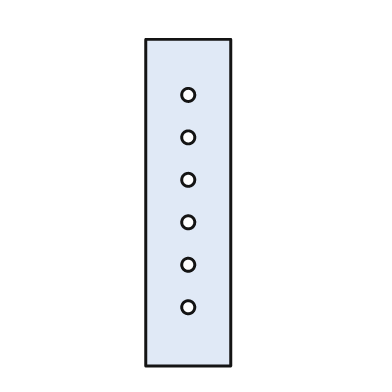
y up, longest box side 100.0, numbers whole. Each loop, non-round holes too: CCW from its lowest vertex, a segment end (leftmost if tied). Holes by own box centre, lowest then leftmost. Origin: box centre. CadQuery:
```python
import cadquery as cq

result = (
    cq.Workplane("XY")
    .moveTo(-13.0, -50.0)
    .lineTo(13.0, -50.0)
    .lineTo(13.0, 50.0)
    .lineTo(-13.0, 50.0)
    .close()
    .moveTo(0.0, -32.0)
    .circle(2.0)
    .moveTo(0.0, -19.0)
    .circle(2.0)
    .moveTo(0.0, -6.0)
    .circle(2.0)
    .moveTo(0.0, 7.0)
    .circle(2.0)
    .moveTo(0.0, 20.0)
    .circle(2.0)
    .moveTo(0.0, 33.0)
    .circle(2.0)
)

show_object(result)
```